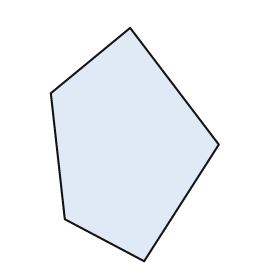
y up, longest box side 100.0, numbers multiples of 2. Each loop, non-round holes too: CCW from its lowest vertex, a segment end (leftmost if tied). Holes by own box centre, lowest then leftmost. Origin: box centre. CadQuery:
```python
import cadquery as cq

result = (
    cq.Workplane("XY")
    .moveTo(4.0, -50.0)
    .lineTo(36.0, 0.0)
    .lineTo(-2.0, 50.0)
    .lineTo(-36.0, 22.0)
    .lineTo(-30.0, -32.0)
    .close()
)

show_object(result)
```